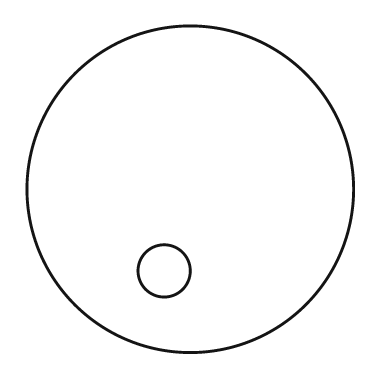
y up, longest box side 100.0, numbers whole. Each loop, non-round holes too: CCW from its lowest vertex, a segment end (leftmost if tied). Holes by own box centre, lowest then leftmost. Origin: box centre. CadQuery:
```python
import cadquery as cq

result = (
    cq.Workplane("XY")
    .moveTo(0.0, 0.0)
    .circle(50.0)
    .moveTo(-8.0, -25.0)
    .circle(8.0)
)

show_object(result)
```